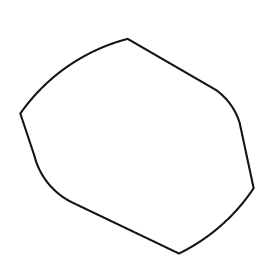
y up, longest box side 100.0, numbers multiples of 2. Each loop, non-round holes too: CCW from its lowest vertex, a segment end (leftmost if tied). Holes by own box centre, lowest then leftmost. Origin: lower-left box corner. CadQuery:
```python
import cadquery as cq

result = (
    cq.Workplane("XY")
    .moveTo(68.0, 0.0)
    .threePointArc((86.0, 12.0), (100.0, 28.0))
    .lineTo(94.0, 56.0)
    .threePointArc((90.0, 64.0), (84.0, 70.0))
    .lineTo(46.0, 92.0)
    .threePointArc((20.0, 80.0), (0.0, 60.0))
    .lineTo(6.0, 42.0)
    .threePointArc((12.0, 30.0), (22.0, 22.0))
    .close()
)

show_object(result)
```